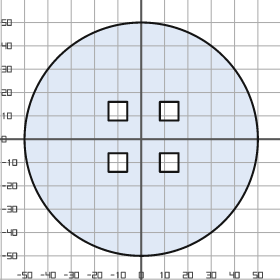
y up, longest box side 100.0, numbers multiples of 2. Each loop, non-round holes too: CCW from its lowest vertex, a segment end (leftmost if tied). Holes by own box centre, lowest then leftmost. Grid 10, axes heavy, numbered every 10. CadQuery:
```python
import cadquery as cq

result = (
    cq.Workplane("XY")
    .moveTo(0.0, 0.0)
    .circle(50.0)
    .moveTo(-14.0, -14.0)
    .lineTo(-6.0, -14.0)
    .lineTo(-6.0, -6.0)
    .lineTo(-14.0, -6.0)
    .close()
    .moveTo(8.0, -14.0)
    .lineTo(16.0, -14.0)
    .lineTo(16.0, -6.0)
    .lineTo(8.0, -6.0)
    .close()
    .moveTo(-14.0, 8.0)
    .lineTo(-6.0, 8.0)
    .lineTo(-6.0, 16.0)
    .lineTo(-14.0, 16.0)
    .close()
    .moveTo(8.0, 8.0)
    .lineTo(16.0, 8.0)
    .lineTo(16.0, 16.0)
    .lineTo(8.0, 16.0)
    .close()
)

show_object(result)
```